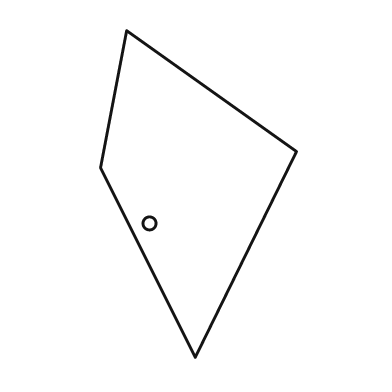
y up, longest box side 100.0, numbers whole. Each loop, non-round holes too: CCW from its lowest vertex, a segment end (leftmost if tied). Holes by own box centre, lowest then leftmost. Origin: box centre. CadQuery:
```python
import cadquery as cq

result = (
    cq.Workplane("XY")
    .moveTo(-1.0, -50.0)
    .lineTo(30.0, 13.0)
    .lineTo(-22.0, 50.0)
    .lineTo(-30.0, 8.0)
    .close()
    .moveTo(-15.0, -9.0)
    .circle(2.0)
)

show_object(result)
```